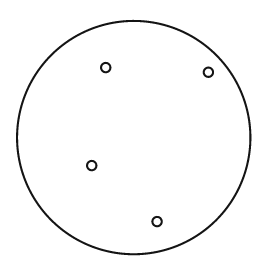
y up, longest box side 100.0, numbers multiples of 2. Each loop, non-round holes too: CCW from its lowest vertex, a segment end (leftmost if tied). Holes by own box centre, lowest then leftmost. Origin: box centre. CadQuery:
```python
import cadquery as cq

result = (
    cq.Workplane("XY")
    .moveTo(0.0, 0.0)
    .circle(50.0)
    .moveTo(10.0, -36.0)
    .circle(2.0)
    .moveTo(-18.0, -12.0)
    .circle(2.0)
    .moveTo(32.0, 28.0)
    .circle(2.0)
    .moveTo(-12.0, 30.0)
    .circle(2.0)
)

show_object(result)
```